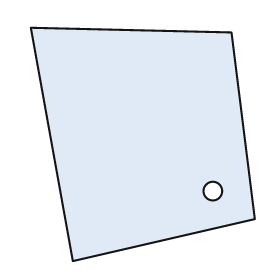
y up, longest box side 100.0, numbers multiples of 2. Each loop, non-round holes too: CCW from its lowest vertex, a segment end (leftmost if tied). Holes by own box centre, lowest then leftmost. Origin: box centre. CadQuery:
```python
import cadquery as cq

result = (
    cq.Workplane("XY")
    .moveTo(-30.0, -50.0)
    .lineTo(48.0, -32.0)
    .lineTo(38.0, 48.0)
    .lineTo(-48.0, 50.0)
    .close()
    .moveTo(30.0, -20.0)
    .circle(4.0)
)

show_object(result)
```